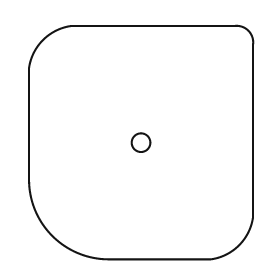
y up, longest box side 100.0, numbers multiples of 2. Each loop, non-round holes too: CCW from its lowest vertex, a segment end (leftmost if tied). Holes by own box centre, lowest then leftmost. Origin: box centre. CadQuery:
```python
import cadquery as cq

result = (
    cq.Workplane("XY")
    .moveTo(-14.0, -50.0)
    .lineTo(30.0, -50.0)
    .threePointArc((42.0, -44.0), (48.0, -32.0))
    .lineTo(48.0, 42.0)
    .threePointArc((46.0, 48.0), (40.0, 50.0))
    .lineTo(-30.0, 50.0)
    .threePointArc((-42.0, 44.0), (-48.0, 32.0))
    .lineTo(-48.0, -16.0)
    .threePointArc((-38.0, -40.0), (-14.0, -50.0))
    .close()
    .moveTo(0.0, 0.0)
    .circle(4.0)
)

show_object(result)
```